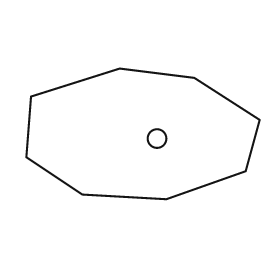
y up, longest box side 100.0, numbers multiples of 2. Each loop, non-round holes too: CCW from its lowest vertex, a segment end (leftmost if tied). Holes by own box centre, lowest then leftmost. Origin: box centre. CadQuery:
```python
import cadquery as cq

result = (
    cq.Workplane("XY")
    .moveTo(10.0, -28.0)
    .lineTo(44.0, -16.0)
    .lineTo(50.0, 6.0)
    .lineTo(22.0, 24.0)
    .lineTo(-10.0, 28.0)
    .lineTo(-48.0, 16.0)
    .lineTo(-50.0, -10.0)
    .lineTo(-26.0, -26.0)
    .close()
    .moveTo(6.0, -2.0)
    .circle(4.0)
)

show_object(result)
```